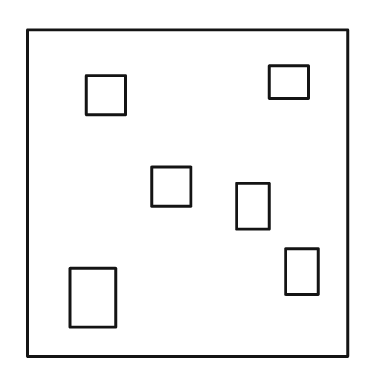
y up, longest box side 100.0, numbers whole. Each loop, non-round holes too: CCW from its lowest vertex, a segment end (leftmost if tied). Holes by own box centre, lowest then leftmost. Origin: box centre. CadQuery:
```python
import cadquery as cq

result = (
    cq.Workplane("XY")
    .moveTo(-49.0, -50.0)
    .lineTo(49.0, -50.0)
    .lineTo(49.0, 50.0)
    .lineTo(-49.0, 50.0)
    .close()
    .moveTo(-36.0, -41.0)
    .lineTo(-22.0, -41.0)
    .lineTo(-22.0, -23.0)
    .lineTo(-36.0, -23.0)
    .close()
    .moveTo(30.0, -31.0)
    .lineTo(40.0, -31.0)
    .lineTo(40.0, -17.0)
    .lineTo(30.0, -17.0)
    .close()
    .moveTo(15.0, -11.0)
    .lineTo(25.0, -11.0)
    .lineTo(25.0, 3.0)
    .lineTo(15.0, 3.0)
    .close()
    .moveTo(-11.0, -4.0)
    .lineTo(1.0, -4.0)
    .lineTo(1.0, 8.0)
    .lineTo(-11.0, 8.0)
    .close()
    .moveTo(-31.0, 24.0)
    .lineTo(-19.0, 24.0)
    .lineTo(-19.0, 36.0)
    .lineTo(-31.0, 36.0)
    .close()
    .moveTo(25.0, 29.0)
    .lineTo(37.0, 29.0)
    .lineTo(37.0, 39.0)
    .lineTo(25.0, 39.0)
    .close()
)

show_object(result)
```